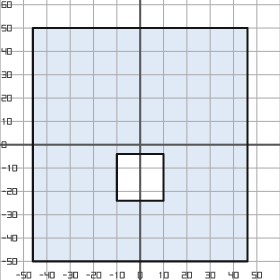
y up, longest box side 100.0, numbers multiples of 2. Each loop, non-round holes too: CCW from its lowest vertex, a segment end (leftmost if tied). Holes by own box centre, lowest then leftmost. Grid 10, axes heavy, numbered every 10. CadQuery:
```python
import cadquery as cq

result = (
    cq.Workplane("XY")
    .moveTo(-46.0, -50.0)
    .lineTo(46.0, -50.0)
    .lineTo(46.0, 50.0)
    .lineTo(-46.0, 50.0)
    .close()
    .moveTo(-10.0, -24.0)
    .lineTo(10.0, -24.0)
    .lineTo(10.0, -4.0)
    .lineTo(-10.0, -4.0)
    .close()
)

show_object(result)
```